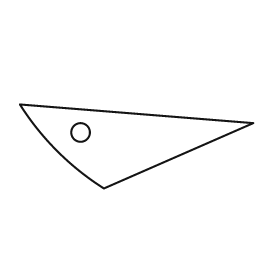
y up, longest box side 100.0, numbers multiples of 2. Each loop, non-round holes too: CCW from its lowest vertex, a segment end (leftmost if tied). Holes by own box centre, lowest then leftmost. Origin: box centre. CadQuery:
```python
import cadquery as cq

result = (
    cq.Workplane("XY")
    .moveTo(-14.0, -18.0)
    .lineTo(50.0, 10.0)
    .lineTo(-50.0, 18.0)
    .threePointArc((-34.0, -2.0), (-14.0, -18.0))
    .close()
    .moveTo(-24.0, 6.0)
    .circle(4.0)
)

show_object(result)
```